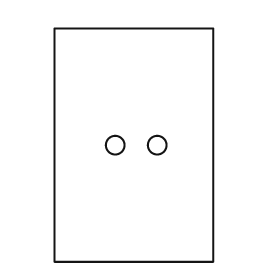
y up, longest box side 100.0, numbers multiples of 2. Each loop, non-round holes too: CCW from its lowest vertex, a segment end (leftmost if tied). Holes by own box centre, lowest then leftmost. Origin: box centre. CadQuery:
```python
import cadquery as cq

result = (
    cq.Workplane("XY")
    .moveTo(-34.0, -50.0)
    .lineTo(34.0, -50.0)
    .lineTo(34.0, 50.0)
    .lineTo(-34.0, 50.0)
    .close()
    .moveTo(-8.0, 0.0)
    .circle(4.0)
    .moveTo(10.0, 0.0)
    .circle(4.0)
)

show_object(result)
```